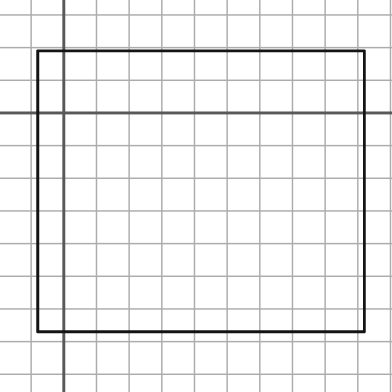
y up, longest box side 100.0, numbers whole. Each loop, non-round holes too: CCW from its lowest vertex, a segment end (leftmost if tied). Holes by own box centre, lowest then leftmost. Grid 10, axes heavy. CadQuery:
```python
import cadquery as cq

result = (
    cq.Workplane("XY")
    .moveTo(-8.0, -67.0)
    .lineTo(92.0, -67.0)
    .lineTo(92.0, 19.0)
    .lineTo(-8.0, 19.0)
    .close()
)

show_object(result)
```